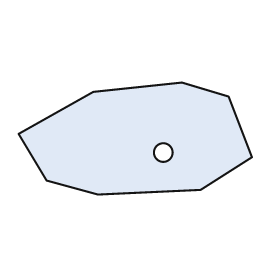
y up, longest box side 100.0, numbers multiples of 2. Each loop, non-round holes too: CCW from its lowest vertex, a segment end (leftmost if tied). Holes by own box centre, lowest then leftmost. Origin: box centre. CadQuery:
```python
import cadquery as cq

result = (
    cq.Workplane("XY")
    .moveTo(-16.0, -24.0)
    .lineTo(28.0, -22.0)
    .lineTo(50.0, -8.0)
    .lineTo(40.0, 18.0)
    .lineTo(20.0, 24.0)
    .lineTo(-18.0, 20.0)
    .lineTo(-50.0, 2.0)
    .lineTo(-38.0, -18.0)
    .close()
    .moveTo(12.0, -6.0)
    .circle(4.0)
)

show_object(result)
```